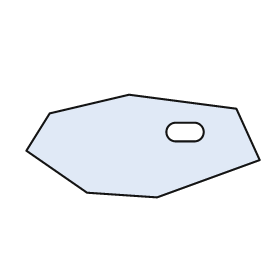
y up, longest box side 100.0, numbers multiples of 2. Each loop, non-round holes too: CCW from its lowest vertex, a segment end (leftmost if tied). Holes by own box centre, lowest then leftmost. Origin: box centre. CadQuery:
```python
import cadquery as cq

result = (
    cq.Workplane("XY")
    .moveTo(6.0, -22.0)
    .lineTo(50.0, -6.0)
    .lineTo(40.0, 16.0)
    .lineTo(-6.0, 22.0)
    .lineTo(-40.0, 14.0)
    .lineTo(-50.0, -2.0)
    .lineTo(-24.0, -20.0)
    .close()
    .moveTo(14.0, 2.0)
    .lineTo(22.0, 2.0)
    .threePointArc((26.0, 6.0), (22.0, 10.0))
    .lineTo(14.0, 10.0)
    .threePointArc((10.0, 6.0), (14.0, 2.0))
    .close()
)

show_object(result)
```